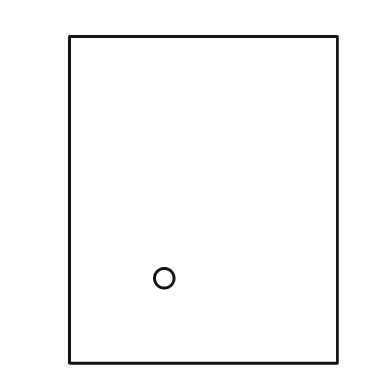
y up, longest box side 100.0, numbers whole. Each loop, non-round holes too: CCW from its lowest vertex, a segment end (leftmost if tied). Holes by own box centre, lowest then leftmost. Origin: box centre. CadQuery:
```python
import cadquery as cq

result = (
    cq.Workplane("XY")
    .moveTo(-41.0, -50.0)
    .lineTo(41.0, -50.0)
    .lineTo(41.0, 50.0)
    .lineTo(-41.0, 50.0)
    .close()
    .moveTo(-12.0, -24.0)
    .circle(3.0)
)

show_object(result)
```